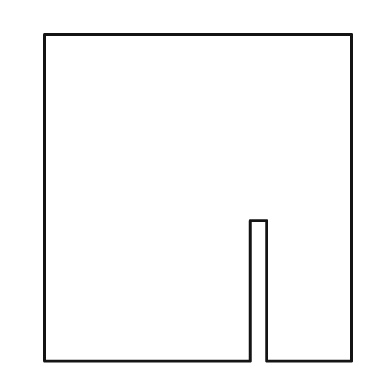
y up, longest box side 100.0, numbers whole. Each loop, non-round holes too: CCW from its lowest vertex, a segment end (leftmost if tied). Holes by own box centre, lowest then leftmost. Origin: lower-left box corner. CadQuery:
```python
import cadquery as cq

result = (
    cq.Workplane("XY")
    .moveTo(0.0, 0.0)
    .lineTo(63.0, 0.0)
    .lineTo(63.0, 43.0)
    .lineTo(68.0, 43.0)
    .lineTo(68.0, 0.0)
    .lineTo(94.0, 0.0)
    .lineTo(94.0, 100.0)
    .lineTo(0.0, 100.0)
    .close()
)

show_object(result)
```